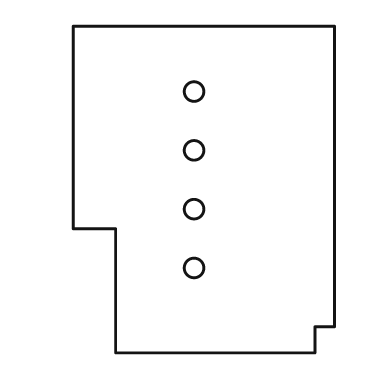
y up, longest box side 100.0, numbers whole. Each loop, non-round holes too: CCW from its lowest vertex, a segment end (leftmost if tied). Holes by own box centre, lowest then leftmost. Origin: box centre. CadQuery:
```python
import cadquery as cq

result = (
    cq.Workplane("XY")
    .moveTo(-27.0, -50.0)
    .lineTo(34.0, -50.0)
    .lineTo(34.0, -42.0)
    .lineTo(40.0, -42.0)
    .lineTo(40.0, 50.0)
    .lineTo(-40.0, 50.0)
    .lineTo(-40.0, -12.0)
    .lineTo(-27.0, -12.0)
    .close()
    .moveTo(-3.0, -24.0)
    .circle(3.0)
    .moveTo(-3.0, -6.0)
    .circle(3.0)
    .moveTo(-3.0, 12.0)
    .circle(3.0)
    .moveTo(-3.0, 30.0)
    .circle(3.0)
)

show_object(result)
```